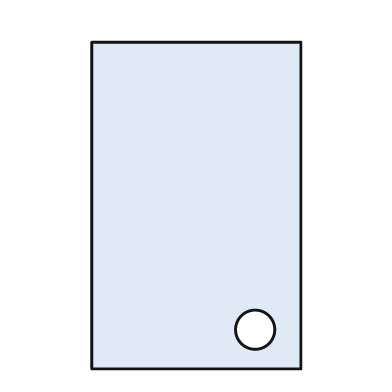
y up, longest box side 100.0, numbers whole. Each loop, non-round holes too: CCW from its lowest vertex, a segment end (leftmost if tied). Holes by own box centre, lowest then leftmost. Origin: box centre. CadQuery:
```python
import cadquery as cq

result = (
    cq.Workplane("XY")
    .moveTo(-32.0, -50.0)
    .lineTo(32.0, -50.0)
    .lineTo(32.0, 50.0)
    .lineTo(-32.0, 50.0)
    .close()
    .moveTo(18.0, -38.0)
    .circle(6.0)
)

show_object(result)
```